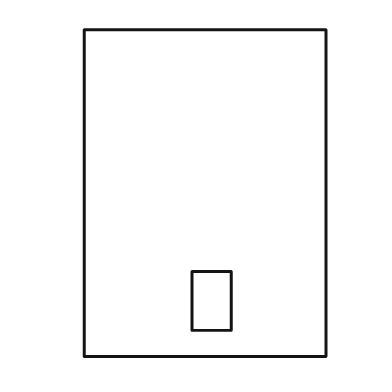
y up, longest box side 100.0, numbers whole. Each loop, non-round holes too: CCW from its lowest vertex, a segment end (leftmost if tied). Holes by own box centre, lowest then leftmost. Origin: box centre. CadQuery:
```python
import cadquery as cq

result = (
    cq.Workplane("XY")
    .moveTo(-37.0, -50.0)
    .lineTo(37.0, -50.0)
    .lineTo(37.0, 50.0)
    .lineTo(-37.0, 50.0)
    .close()
    .moveTo(-4.0, -42.0)
    .lineTo(8.0, -42.0)
    .lineTo(8.0, -24.0)
    .lineTo(-4.0, -24.0)
    .close()
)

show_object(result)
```